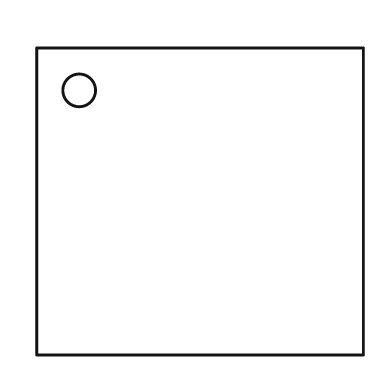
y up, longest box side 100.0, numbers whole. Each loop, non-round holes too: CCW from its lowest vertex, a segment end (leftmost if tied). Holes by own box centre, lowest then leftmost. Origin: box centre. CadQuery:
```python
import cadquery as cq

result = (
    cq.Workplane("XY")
    .moveTo(-50.0, -47.0)
    .lineTo(50.0, -47.0)
    .lineTo(50.0, 47.0)
    .lineTo(-50.0, 47.0)
    .close()
    .moveTo(-37.0, 34.0)
    .circle(5.0)
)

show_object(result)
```